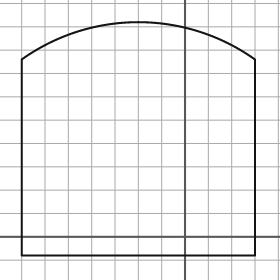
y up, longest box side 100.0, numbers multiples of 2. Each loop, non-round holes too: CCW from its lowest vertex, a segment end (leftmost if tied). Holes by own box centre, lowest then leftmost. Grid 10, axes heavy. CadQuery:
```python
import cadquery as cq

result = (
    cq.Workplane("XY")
    .moveTo(-70.0, -8.0)
    .lineTo(30.0, -8.0)
    .lineTo(30.0, 76.0)
    .threePointArc((-20.0, 92.0), (-70.0, 76.0))
    .close()
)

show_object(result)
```